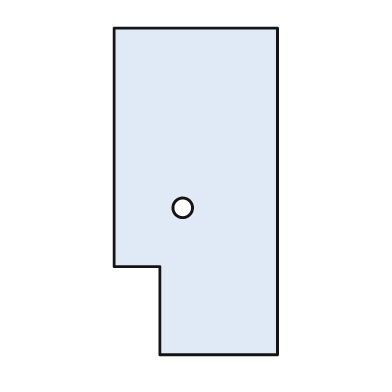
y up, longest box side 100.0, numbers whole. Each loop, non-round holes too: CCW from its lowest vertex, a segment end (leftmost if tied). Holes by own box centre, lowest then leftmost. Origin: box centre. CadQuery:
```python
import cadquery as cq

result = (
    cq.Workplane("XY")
    .moveTo(-11.0, -50.0)
    .lineTo(25.0, -50.0)
    .lineTo(25.0, 50.0)
    .lineTo(-25.0, 50.0)
    .lineTo(-25.0, -23.0)
    .lineTo(-11.0, -23.0)
    .close()
    .moveTo(-4.0, -5.0)
    .circle(3.0)
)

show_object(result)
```